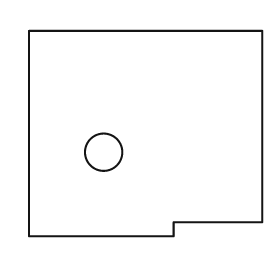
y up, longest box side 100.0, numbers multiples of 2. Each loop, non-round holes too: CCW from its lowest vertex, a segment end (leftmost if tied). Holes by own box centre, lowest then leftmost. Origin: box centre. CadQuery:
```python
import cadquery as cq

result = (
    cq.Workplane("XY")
    .moveTo(-50.0, -44.0)
    .lineTo(12.0, -44.0)
    .lineTo(12.0, -38.0)
    .lineTo(50.0, -38.0)
    .lineTo(50.0, 44.0)
    .lineTo(-50.0, 44.0)
    .close()
    .moveTo(-18.0, -8.0)
    .circle(8.0)
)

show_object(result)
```